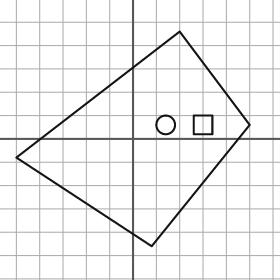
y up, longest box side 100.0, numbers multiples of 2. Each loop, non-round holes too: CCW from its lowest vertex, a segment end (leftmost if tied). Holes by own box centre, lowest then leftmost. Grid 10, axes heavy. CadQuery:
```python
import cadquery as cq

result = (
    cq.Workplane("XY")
    .moveTo(8.0, -46.0)
    .lineTo(50.0, 6.0)
    .lineTo(20.0, 46.0)
    .lineTo(-50.0, -8.0)
    .close()
    .moveTo(14.0, 6.0)
    .circle(4.0)
    .moveTo(26.0, 2.0)
    .lineTo(34.0, 2.0)
    .lineTo(34.0, 10.0)
    .lineTo(26.0, 10.0)
    .close()
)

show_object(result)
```